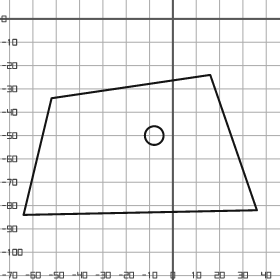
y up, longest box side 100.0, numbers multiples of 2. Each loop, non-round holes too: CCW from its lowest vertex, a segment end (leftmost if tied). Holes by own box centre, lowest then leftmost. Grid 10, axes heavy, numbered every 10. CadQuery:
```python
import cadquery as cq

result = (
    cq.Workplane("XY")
    .moveTo(-64.0, -84.0)
    .lineTo(36.0, -82.0)
    .lineTo(16.0, -24.0)
    .lineTo(-52.0, -34.0)
    .close()
    .moveTo(-8.0, -50.0)
    .circle(4.0)
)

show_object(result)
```